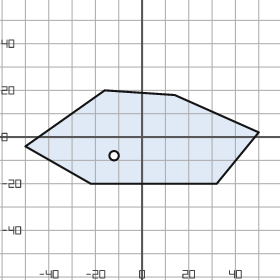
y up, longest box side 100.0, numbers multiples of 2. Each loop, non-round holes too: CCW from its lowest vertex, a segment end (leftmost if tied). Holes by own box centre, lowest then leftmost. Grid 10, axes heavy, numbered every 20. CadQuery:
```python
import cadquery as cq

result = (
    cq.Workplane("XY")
    .moveTo(-22.0, -20.0)
    .lineTo(32.0, -20.0)
    .lineTo(50.0, 2.0)
    .lineTo(14.0, 18.0)
    .lineTo(-16.0, 20.0)
    .lineTo(-50.0, -4.0)
    .close()
    .moveTo(-12.0, -8.0)
    .circle(2.0)
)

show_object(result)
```